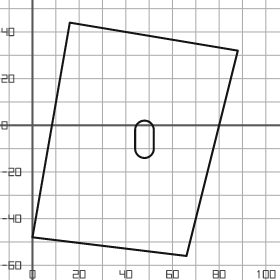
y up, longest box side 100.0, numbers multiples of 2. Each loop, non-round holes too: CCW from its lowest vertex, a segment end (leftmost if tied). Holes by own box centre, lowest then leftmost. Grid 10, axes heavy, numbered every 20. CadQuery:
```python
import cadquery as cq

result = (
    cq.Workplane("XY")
    .moveTo(66.0, -56.0)
    .lineTo(88.0, 32.0)
    .lineTo(16.0, 44.0)
    .lineTo(0.0, -48.0)
    .close()
    .moveTo(44.0, -10.0)
    .threePointArc((48.0, -14.0), (52.0, -10.0))
    .lineTo(52.0, -2.0)
    .threePointArc((48.0, 2.0), (44.0, -2.0))
    .close()
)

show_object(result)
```